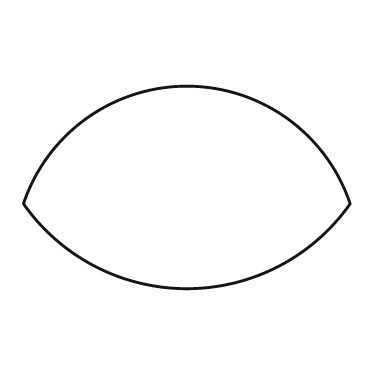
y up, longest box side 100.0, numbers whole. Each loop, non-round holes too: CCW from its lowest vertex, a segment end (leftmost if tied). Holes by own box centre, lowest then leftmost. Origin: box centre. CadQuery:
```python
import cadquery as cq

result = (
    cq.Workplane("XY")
    .moveTo(-50.0, -5.0)
    .threePointArc((0.0, -31.0), (50.0, -5.0))
    .threePointArc((0.0, 31.0), (-50.0, -5.0))
    .close()
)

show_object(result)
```